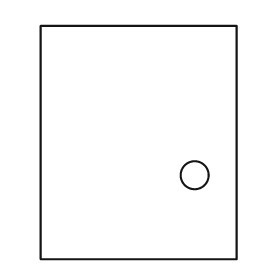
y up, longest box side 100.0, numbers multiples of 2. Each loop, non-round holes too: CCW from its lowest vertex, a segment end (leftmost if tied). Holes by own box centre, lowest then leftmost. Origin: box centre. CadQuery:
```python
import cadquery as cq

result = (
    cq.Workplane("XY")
    .moveTo(-42.0, -50.0)
    .lineTo(42.0, -50.0)
    .lineTo(42.0, 50.0)
    .lineTo(-42.0, 50.0)
    .close()
    .moveTo(24.0, -14.0)
    .circle(6.0)
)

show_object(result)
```